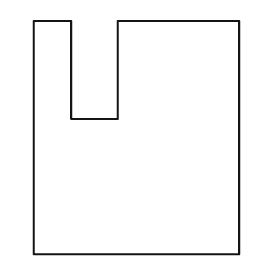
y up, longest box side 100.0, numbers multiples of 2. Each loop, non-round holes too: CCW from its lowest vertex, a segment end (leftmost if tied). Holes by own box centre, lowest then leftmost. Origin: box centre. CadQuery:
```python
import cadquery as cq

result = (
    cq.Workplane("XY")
    .moveTo(-44.0, -50.0)
    .lineTo(44.0, -50.0)
    .lineTo(44.0, 50.0)
    .lineTo(-8.0, 50.0)
    .lineTo(-8.0, 8.0)
    .lineTo(-28.0, 8.0)
    .lineTo(-28.0, 50.0)
    .lineTo(-44.0, 50.0)
    .close()
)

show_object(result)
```